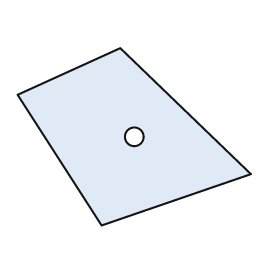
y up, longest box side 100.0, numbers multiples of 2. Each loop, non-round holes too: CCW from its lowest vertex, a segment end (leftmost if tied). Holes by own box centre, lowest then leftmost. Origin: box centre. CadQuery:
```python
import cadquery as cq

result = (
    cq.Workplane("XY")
    .moveTo(-14.0, -38.0)
    .lineTo(50.0, -16.0)
    .lineTo(-6.0, 38.0)
    .lineTo(-50.0, 18.0)
    .close()
    .moveTo(0.0, 0.0)
    .circle(4.0)
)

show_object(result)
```